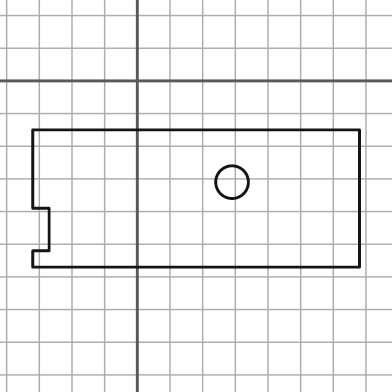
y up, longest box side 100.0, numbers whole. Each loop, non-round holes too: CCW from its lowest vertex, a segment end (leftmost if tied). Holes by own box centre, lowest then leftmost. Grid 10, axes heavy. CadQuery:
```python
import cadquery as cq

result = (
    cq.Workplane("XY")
    .moveTo(-32.0, -57.0)
    .lineTo(68.0, -57.0)
    .lineTo(68.0, -15.0)
    .lineTo(-32.0, -15.0)
    .lineTo(-32.0, -39.0)
    .lineTo(-27.0, -39.0)
    .lineTo(-27.0, -52.0)
    .lineTo(-32.0, -52.0)
    .close()
    .moveTo(29.0, -31.0)
    .circle(5.0)
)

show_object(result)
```